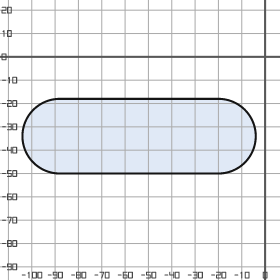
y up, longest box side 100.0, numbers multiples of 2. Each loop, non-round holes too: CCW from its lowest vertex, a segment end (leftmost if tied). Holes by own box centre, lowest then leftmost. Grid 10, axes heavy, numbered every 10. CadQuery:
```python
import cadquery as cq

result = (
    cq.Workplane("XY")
    .moveTo(-88.0, -50.0)
    .lineTo(-20.0, -50.0)
    .threePointArc((-4.0, -34.0), (-20.0, -18.0))
    .lineTo(-88.0, -18.0)
    .threePointArc((-104.0, -34.0), (-88.0, -50.0))
    .close()
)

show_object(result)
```